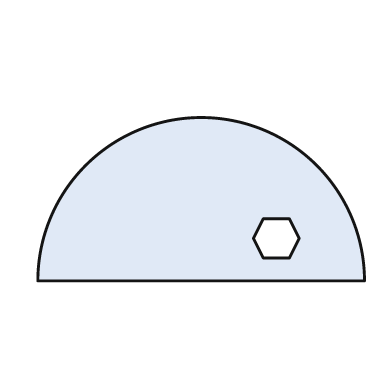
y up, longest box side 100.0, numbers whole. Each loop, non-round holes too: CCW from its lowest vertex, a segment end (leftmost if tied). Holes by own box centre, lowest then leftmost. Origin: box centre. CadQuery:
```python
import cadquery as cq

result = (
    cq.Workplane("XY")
    .moveTo(-50.0, -25.0)
    .lineTo(50.0, -25.0)
    .threePointArc((0.0, 25.0), (-50.0, -25.0))
    .close()
    .moveTo(19.0, -18.0)
    .lineTo(27.0, -18.0)
    .lineTo(30.0, -12.0)
    .lineTo(27.0, -6.0)
    .lineTo(19.0, -6.0)
    .lineTo(16.0, -12.0)
    .close()
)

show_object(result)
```